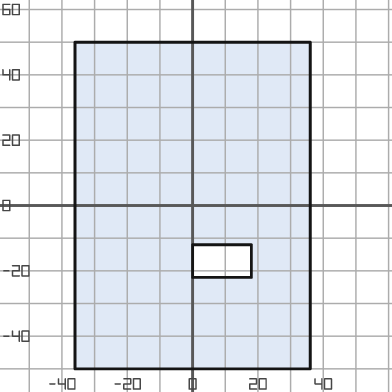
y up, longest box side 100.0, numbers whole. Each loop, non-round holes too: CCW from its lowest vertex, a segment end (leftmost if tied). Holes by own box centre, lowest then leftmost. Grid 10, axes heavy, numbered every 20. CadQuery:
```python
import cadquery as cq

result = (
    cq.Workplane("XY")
    .moveTo(-36.0, -50.0)
    .lineTo(36.0, -50.0)
    .lineTo(36.0, 50.0)
    .lineTo(-36.0, 50.0)
    .close()
    .moveTo(0.0, -22.0)
    .lineTo(18.0, -22.0)
    .lineTo(18.0, -12.0)
    .lineTo(0.0, -12.0)
    .close()
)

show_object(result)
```